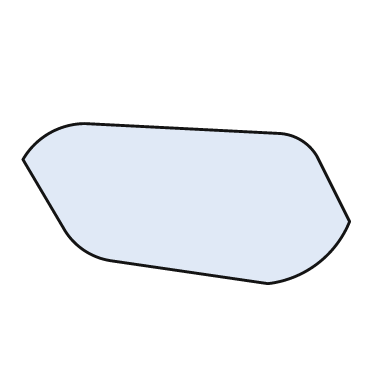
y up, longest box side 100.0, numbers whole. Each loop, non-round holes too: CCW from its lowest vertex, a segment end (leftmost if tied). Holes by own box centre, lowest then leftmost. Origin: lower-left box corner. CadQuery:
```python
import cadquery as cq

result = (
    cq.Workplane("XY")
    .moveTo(75.0, 0.0)
    .threePointArc((90.0, 6.0), (100.0, 19.0))
    .lineTo(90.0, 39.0)
    .threePointArc((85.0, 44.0), (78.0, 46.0))
    .lineTo(19.0, 49.0)
    .threePointArc((8.0, 46.0), (0.0, 38.0))
    .lineTo(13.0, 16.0)
    .threePointArc((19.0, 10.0), (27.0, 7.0))
    .close()
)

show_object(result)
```